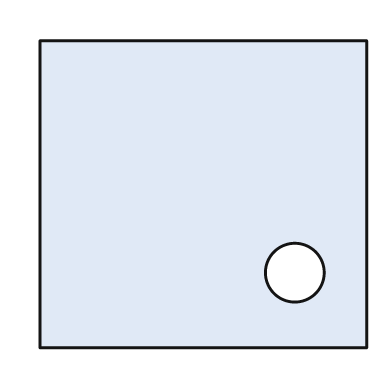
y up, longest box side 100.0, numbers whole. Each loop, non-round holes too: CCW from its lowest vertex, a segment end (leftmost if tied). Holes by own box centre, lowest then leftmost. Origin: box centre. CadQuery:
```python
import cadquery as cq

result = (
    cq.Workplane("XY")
    .moveTo(-50.0, -47.0)
    .lineTo(50.0, -47.0)
    .lineTo(50.0, 47.0)
    .lineTo(-50.0, 47.0)
    .close()
    .moveTo(28.0, -24.0)
    .circle(9.0)
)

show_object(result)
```